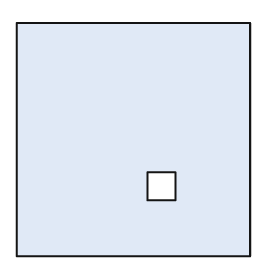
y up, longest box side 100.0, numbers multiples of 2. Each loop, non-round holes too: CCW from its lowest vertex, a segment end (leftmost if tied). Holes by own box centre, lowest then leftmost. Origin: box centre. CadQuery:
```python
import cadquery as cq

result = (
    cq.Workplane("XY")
    .moveTo(-50.0, -50.0)
    .lineTo(50.0, -50.0)
    .lineTo(50.0, 50.0)
    .lineTo(-50.0, 50.0)
    .close()
    .moveTo(6.0, -26.0)
    .lineTo(18.0, -26.0)
    .lineTo(18.0, -14.0)
    .lineTo(6.0, -14.0)
    .close()
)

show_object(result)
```